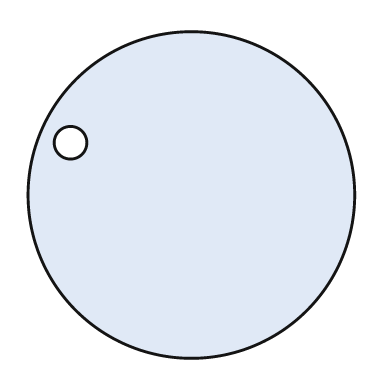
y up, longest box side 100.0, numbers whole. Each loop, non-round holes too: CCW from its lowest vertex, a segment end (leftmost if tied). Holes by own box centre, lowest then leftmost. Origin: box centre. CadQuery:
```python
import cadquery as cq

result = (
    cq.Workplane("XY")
    .moveTo(0.0, 0.0)
    .circle(50.0)
    .moveTo(-37.0, 16.0)
    .circle(5.0)
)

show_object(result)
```